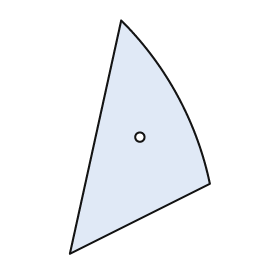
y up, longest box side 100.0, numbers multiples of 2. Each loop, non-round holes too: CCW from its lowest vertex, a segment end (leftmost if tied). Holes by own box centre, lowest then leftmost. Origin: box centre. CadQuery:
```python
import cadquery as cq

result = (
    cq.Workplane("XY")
    .moveTo(-30.0, -50.0)
    .lineTo(30.0, -20.0)
    .threePointArc((16.0, 18.0), (-8.0, 50.0))
    .close()
    .moveTo(0.0, 0.0)
    .circle(2.0)
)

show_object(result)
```